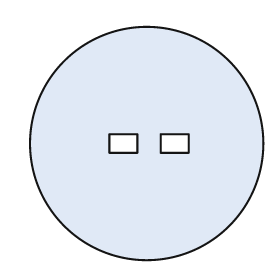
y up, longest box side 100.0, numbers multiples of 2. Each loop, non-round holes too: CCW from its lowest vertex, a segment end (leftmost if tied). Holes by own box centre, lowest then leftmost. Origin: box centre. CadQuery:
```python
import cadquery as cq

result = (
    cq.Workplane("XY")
    .moveTo(0.0, 0.0)
    .circle(50.0)
    .moveTo(-16.0, -4.0)
    .lineTo(-4.0, -4.0)
    .lineTo(-4.0, 4.0)
    .lineTo(-16.0, 4.0)
    .close()
    .moveTo(6.0, -4.0)
    .lineTo(18.0, -4.0)
    .lineTo(18.0, 4.0)
    .lineTo(6.0, 4.0)
    .close()
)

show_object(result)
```